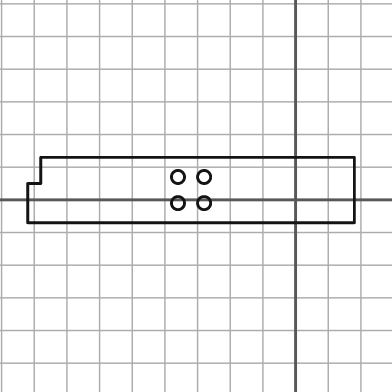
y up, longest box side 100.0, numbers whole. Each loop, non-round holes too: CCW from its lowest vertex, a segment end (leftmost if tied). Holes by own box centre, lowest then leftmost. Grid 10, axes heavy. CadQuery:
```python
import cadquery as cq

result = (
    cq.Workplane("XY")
    .moveTo(-82.0, -7.0)
    .lineTo(18.0, -7.0)
    .lineTo(18.0, 13.0)
    .lineTo(-78.0, 13.0)
    .lineTo(-78.0, 5.0)
    .lineTo(-82.0, 5.0)
    .close()
    .moveTo(-36.0, -1.0)
    .circle(2.0)
    .moveTo(-28.0, -1.0)
    .circle(2.0)
    .moveTo(-36.0, 7.0)
    .circle(2.0)
    .moveTo(-28.0, 7.0)
    .circle(2.0)
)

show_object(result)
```